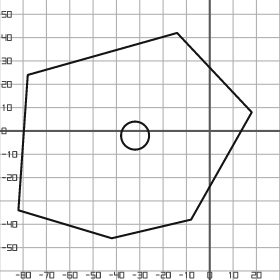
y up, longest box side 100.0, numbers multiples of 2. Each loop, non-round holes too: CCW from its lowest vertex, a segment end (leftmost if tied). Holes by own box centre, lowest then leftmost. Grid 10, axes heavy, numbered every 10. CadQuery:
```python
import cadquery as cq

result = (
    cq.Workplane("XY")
    .moveTo(-42.0, -46.0)
    .lineTo(-8.0, -38.0)
    .lineTo(18.0, 8.0)
    .lineTo(-14.0, 42.0)
    .lineTo(-78.0, 24.0)
    .lineTo(-82.0, -34.0)
    .close()
    .moveTo(-32.0, -2.0)
    .circle(6.0)
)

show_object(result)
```